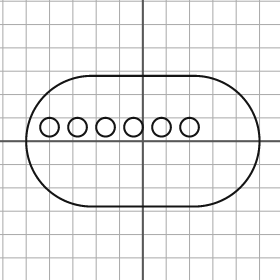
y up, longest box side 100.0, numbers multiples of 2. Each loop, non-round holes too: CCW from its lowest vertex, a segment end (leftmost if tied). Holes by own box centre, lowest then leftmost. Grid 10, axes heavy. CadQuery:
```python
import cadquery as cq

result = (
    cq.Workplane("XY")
    .moveTo(-22.0, -28.0)
    .lineTo(22.0, -28.0)
    .threePointArc((50.0, 0.0), (22.0, 28.0))
    .lineTo(-22.0, 28.0)
    .threePointArc((-50.0, 0.0), (-22.0, -28.0))
    .close()
    .moveTo(-40.0, 6.0)
    .circle(4.0)
    .moveTo(-28.0, 6.0)
    .circle(4.0)
    .moveTo(-16.0, 6.0)
    .circle(4.0)
    .moveTo(-4.0, 6.0)
    .circle(4.0)
    .moveTo(8.0, 6.0)
    .circle(4.0)
    .moveTo(20.0, 6.0)
    .circle(4.0)
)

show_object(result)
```